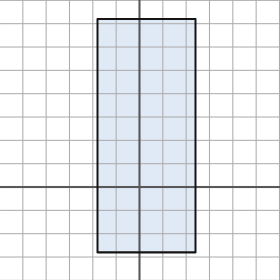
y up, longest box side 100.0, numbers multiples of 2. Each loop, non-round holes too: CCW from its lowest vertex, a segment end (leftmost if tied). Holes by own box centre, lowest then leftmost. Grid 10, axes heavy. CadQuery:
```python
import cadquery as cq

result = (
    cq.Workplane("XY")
    .moveTo(-18.0, -28.0)
    .lineTo(24.0, -28.0)
    .lineTo(24.0, 72.0)
    .lineTo(-18.0, 72.0)
    .close()
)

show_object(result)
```